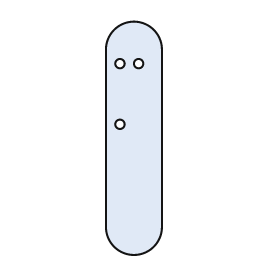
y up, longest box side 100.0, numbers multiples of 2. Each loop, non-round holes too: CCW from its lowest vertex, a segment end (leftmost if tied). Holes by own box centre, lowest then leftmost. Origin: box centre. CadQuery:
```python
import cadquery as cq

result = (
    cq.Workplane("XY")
    .moveTo(-12.0, -38.0)
    .threePointArc((0.0, -50.0), (12.0, -38.0))
    .lineTo(12.0, 38.0)
    .threePointArc((0.0, 50.0), (-12.0, 38.0))
    .close()
    .moveTo(-6.0, 6.0)
    .circle(2.0)
    .moveTo(-6.0, 32.0)
    .circle(2.0)
    .moveTo(2.0, 32.0)
    .circle(2.0)
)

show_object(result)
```